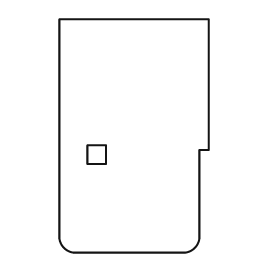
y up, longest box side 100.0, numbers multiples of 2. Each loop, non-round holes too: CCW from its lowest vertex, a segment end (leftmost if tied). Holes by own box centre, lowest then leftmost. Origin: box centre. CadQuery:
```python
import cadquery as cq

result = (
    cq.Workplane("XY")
    .moveTo(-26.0, -50.0)
    .lineTo(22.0, -50.0)
    .threePointArc((26.0, -48.0), (28.0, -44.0))
    .lineTo(28.0, -6.0)
    .lineTo(32.0, -6.0)
    .lineTo(32.0, 50.0)
    .lineTo(-32.0, 50.0)
    .lineTo(-32.0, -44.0)
    .threePointArc((-30.0, -48.0), (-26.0, -50.0))
    .close()
    .moveTo(-20.0, -12.0)
    .lineTo(-12.0, -12.0)
    .lineTo(-12.0, -4.0)
    .lineTo(-20.0, -4.0)
    .close()
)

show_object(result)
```